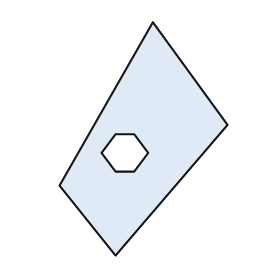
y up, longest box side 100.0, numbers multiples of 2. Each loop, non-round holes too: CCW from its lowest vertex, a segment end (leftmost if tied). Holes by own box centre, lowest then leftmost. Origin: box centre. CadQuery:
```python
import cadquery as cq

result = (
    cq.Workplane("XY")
    .moveTo(-12.0, -50.0)
    .lineTo(36.0, 6.0)
    .lineTo(4.0, 50.0)
    .lineTo(-36.0, -20.0)
    .close()
    .moveTo(-12.0, -14.0)
    .lineTo(-4.0, -14.0)
    .lineTo(2.0, -6.0)
    .lineTo(-4.0, 2.0)
    .lineTo(-12.0, 2.0)
    .lineTo(-18.0, -6.0)
    .close()
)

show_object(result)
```